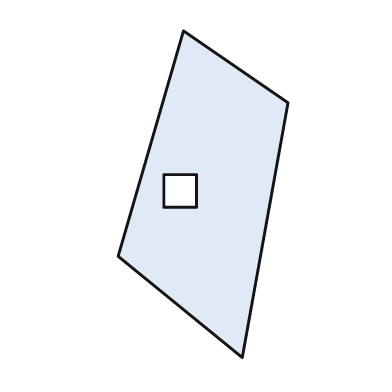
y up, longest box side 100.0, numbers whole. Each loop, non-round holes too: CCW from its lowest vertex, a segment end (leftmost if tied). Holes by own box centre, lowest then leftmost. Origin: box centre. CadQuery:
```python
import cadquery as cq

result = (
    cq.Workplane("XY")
    .moveTo(12.0, -50.0)
    .lineTo(26.0, 28.0)
    .lineTo(-6.0, 50.0)
    .lineTo(-26.0, -19.0)
    .close()
    .moveTo(-12.0, -4.0)
    .lineTo(-2.0, -4.0)
    .lineTo(-2.0, 6.0)
    .lineTo(-12.0, 6.0)
    .close()
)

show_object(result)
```